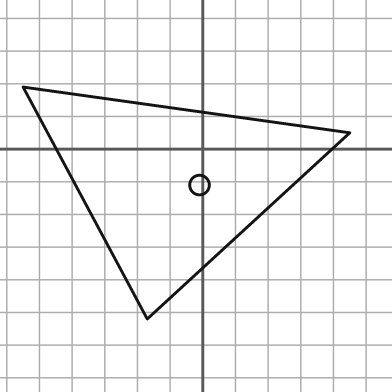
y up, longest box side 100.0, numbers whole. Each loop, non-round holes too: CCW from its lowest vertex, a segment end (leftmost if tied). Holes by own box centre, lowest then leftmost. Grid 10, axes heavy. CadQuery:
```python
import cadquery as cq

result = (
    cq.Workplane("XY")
    .moveTo(-17.0, -52.0)
    .lineTo(45.0, 5.0)
    .lineTo(-55.0, 19.0)
    .close()
    .moveTo(-1.0, -11.0)
    .circle(3.0)
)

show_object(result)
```